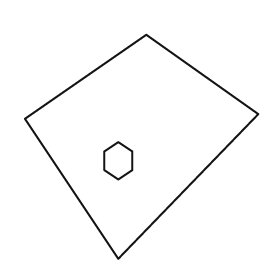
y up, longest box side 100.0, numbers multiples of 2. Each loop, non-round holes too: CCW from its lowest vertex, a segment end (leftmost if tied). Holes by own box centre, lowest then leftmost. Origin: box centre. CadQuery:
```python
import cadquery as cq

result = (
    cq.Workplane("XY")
    .moveTo(-10.0, -48.0)
    .lineTo(50.0, 14.0)
    .lineTo(2.0, 48.0)
    .lineTo(-50.0, 12.0)
    .close()
    .moveTo(-10.0, -14.0)
    .lineTo(-4.0, -10.0)
    .lineTo(-4.0, -2.0)
    .lineTo(-10.0, 2.0)
    .lineTo(-16.0, -2.0)
    .lineTo(-16.0, -10.0)
    .close()
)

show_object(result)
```